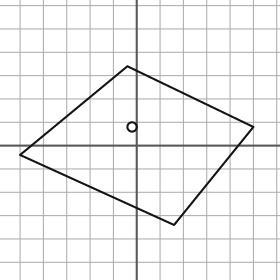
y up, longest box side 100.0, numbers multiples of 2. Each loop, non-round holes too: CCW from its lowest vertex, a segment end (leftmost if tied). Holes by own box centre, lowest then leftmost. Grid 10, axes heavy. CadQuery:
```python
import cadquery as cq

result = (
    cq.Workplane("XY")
    .moveTo(16.0, -34.0)
    .lineTo(50.0, 8.0)
    .lineTo(-4.0, 34.0)
    .lineTo(-50.0, -4.0)
    .close()
    .moveTo(-2.0, 8.0)
    .circle(2.0)
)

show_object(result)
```